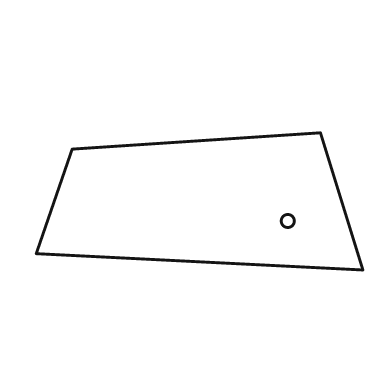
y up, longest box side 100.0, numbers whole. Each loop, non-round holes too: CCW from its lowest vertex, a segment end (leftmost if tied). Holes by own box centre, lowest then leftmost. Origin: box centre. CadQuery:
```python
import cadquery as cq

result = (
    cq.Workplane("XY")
    .moveTo(50.0, -21.0)
    .lineTo(37.0, 21.0)
    .lineTo(-39.0, 16.0)
    .lineTo(-50.0, -16.0)
    .close()
    .moveTo(27.0, -6.0)
    .circle(2.0)
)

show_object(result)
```